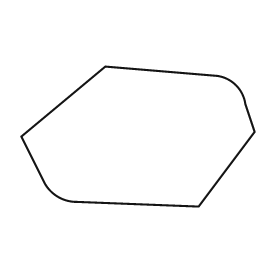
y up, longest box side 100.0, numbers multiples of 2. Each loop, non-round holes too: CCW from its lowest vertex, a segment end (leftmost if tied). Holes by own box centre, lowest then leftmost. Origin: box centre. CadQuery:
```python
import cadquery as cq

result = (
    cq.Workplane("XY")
    .moveTo(26.0, -30.0)
    .lineTo(50.0, 2.0)
    .lineTo(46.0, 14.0)
    .threePointArc((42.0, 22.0), (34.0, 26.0))
    .lineTo(-14.0, 30.0)
    .lineTo(-50.0, 0.0)
    .lineTo(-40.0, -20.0)
    .threePointArc((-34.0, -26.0), (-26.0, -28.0))
    .close()
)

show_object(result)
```